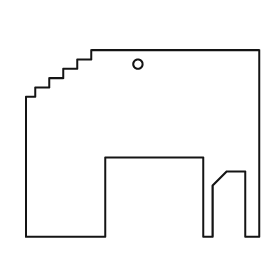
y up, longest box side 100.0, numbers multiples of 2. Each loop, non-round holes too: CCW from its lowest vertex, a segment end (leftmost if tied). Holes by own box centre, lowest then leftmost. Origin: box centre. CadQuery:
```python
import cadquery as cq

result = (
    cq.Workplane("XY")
    .moveTo(-50.0, -40.0)
    .lineTo(-16.0, -40.0)
    .lineTo(-16.0, -6.0)
    .lineTo(26.0, -6.0)
    .lineTo(26.0, -40.0)
    .lineTo(30.0, -40.0)
    .lineTo(30.0, -18.0)
    .lineTo(36.0, -12.0)
    .lineTo(44.0, -12.0)
    .lineTo(44.0, -40.0)
    .lineTo(50.0, -40.0)
    .lineTo(50.0, 40.0)
    .lineTo(-22.0, 40.0)
    .lineTo(-22.0, 36.0)
    .lineTo(-28.0, 36.0)
    .lineTo(-28.0, 32.0)
    .lineTo(-34.0, 32.0)
    .lineTo(-34.0, 28.0)
    .lineTo(-40.0, 28.0)
    .lineTo(-40.0, 24.0)
    .lineTo(-46.0, 24.0)
    .lineTo(-46.0, 20.0)
    .lineTo(-50.0, 20.0)
    .close()
    .moveTo(-2.0, 34.0)
    .circle(2.0)
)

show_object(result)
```